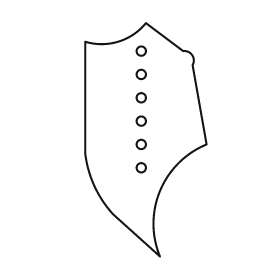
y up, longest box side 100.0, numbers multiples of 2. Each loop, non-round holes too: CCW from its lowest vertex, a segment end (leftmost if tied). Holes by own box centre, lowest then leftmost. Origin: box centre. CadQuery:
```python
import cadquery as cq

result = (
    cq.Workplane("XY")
    .moveTo(6.0, -50.0)
    .threePointArc((6.0, -22.0), (26.0, -2.0))
    .lineTo(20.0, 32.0)
    .threePointArc((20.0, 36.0), (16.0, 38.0))
    .lineTo(0.0, 50.0)
    .threePointArc((-12.0, 42.0), (-26.0, 42.0))
    .lineTo(-26.0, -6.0)
    .threePointArc((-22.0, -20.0), (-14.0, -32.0))
    .close()
    .moveTo(-2.0, -12.0)
    .circle(2.0)
    .moveTo(-2.0, -2.0)
    .circle(2.0)
    .moveTo(-2.0, 8.0)
    .circle(2.0)
    .moveTo(-2.0, 18.0)
    .circle(2.0)
    .moveTo(-2.0, 28.0)
    .circle(2.0)
    .moveTo(-2.0, 38.0)
    .circle(2.0)
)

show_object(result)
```